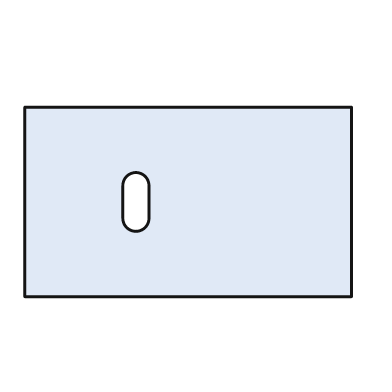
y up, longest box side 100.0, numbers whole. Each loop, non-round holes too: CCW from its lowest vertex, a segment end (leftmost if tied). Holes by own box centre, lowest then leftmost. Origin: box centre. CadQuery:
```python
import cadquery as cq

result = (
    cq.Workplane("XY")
    .moveTo(-50.0, -29.0)
    .lineTo(50.0, -29.0)
    .lineTo(50.0, 29.0)
    .lineTo(-50.0, 29.0)
    .close()
    .moveTo(-20.0, -5.0)
    .threePointArc((-16.0, -9.0), (-12.0, -5.0))
    .lineTo(-12.0, 5.0)
    .threePointArc((-16.0, 9.0), (-20.0, 5.0))
    .close()
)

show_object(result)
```